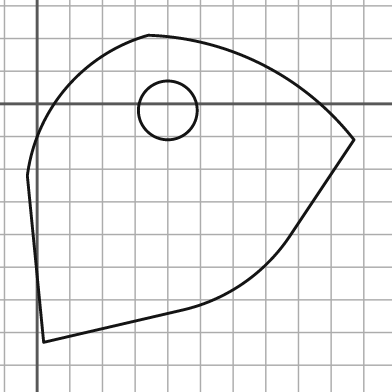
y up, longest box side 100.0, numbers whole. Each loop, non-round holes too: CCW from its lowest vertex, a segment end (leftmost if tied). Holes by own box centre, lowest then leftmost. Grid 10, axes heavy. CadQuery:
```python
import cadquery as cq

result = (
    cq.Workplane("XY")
    .moveTo(2.0, -73.0)
    .lineTo(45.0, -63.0)
    .threePointArc((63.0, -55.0), (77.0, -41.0))
    .lineTo(97.0, -11.0)
    .threePointArc((69.0, 12.0), (34.0, 21.0))
    .threePointArc((9.0, 5.0), (-3.0, -22.0))
    .close()
    .moveTo(40.0, -2.0)
    .circle(9.0)
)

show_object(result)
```